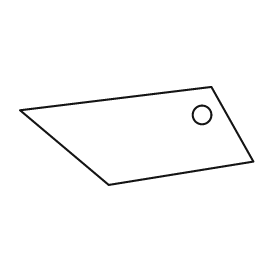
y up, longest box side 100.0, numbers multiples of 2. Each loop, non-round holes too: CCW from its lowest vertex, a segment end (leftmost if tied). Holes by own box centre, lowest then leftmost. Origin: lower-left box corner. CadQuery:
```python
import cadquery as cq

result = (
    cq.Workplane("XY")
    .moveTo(38.0, 0.0)
    .lineTo(100.0, 10.0)
    .lineTo(82.0, 42.0)
    .lineTo(0.0, 32.0)
    .close()
    .moveTo(78.0, 30.0)
    .circle(4.0)
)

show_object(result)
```